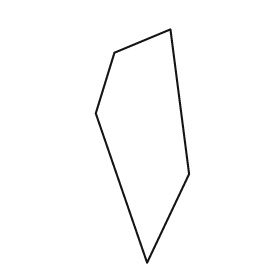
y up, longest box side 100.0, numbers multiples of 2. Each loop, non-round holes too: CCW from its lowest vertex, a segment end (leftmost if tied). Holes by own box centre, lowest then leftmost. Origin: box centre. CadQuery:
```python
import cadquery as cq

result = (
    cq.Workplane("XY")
    .moveTo(2.0, -50.0)
    .lineTo(20.0, -12.0)
    .lineTo(12.0, 50.0)
    .lineTo(-12.0, 40.0)
    .lineTo(-20.0, 14.0)
    .close()
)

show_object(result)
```